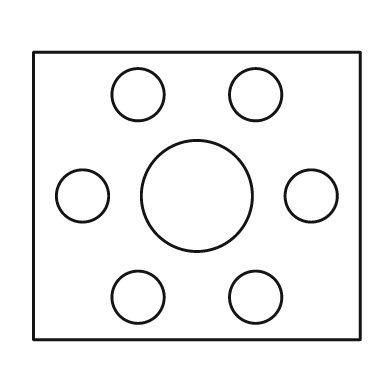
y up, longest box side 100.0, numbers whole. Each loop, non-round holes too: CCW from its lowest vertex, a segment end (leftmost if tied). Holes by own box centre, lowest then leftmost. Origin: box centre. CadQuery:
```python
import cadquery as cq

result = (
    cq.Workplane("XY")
    .moveTo(-50.0, -44.0)
    .lineTo(50.0, -44.0)
    .lineTo(50.0, 44.0)
    .lineTo(-50.0, 44.0)
    .close()
    .moveTo(-18.0, -31.0)
    .circle(8.0)
    .moveTo(18.0, -31.0)
    .circle(8.0)
    .moveTo(-35.0, 0.0)
    .circle(8.0)
    .moveTo(0.0, 0.0)
    .circle(17.0)
    .moveTo(35.0, 0.0)
    .circle(8.0)
    .moveTo(-18.0, 31.0)
    .circle(8.0)
    .moveTo(18.0, 31.0)
    .circle(8.0)
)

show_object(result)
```